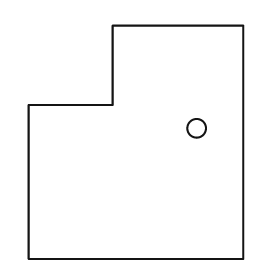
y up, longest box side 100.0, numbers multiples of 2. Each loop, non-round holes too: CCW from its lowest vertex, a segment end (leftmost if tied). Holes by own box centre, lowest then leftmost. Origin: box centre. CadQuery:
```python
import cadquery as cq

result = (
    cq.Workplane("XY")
    .moveTo(-46.0, -50.0)
    .lineTo(46.0, -50.0)
    .lineTo(46.0, 50.0)
    .lineTo(-10.0, 50.0)
    .lineTo(-10.0, 16.0)
    .lineTo(-46.0, 16.0)
    .close()
    .moveTo(26.0, 6.0)
    .circle(4.0)
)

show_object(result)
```